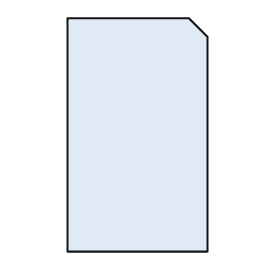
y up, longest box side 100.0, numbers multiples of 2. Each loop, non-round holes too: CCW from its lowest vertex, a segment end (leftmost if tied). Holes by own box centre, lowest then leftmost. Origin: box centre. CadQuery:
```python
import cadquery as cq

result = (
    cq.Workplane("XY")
    .moveTo(-30.0, -50.0)
    .lineTo(30.0, -50.0)
    .lineTo(30.0, 42.0)
    .lineTo(22.0, 50.0)
    .lineTo(-30.0, 50.0)
    .close()
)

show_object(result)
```